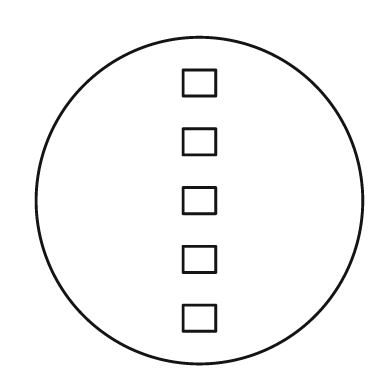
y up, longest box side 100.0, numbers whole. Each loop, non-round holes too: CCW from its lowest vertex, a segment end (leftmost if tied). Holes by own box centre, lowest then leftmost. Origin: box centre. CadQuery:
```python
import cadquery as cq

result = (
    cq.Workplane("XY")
    .moveTo(0.0, 0.0)
    .circle(50.0)
    .moveTo(-5.0, -40.0)
    .lineTo(5.0, -40.0)
    .lineTo(5.0, -32.0)
    .lineTo(-5.0, -32.0)
    .close()
    .moveTo(-5.0, -22.0)
    .lineTo(5.0, -22.0)
    .lineTo(5.0, -14.0)
    .lineTo(-5.0, -14.0)
    .close()
    .moveTo(-5.0, -4.0)
    .lineTo(5.0, -4.0)
    .lineTo(5.0, 4.0)
    .lineTo(-5.0, 4.0)
    .close()
    .moveTo(-5.0, 14.0)
    .lineTo(5.0, 14.0)
    .lineTo(5.0, 22.0)
    .lineTo(-5.0, 22.0)
    .close()
    .moveTo(-5.0, 32.0)
    .lineTo(5.0, 32.0)
    .lineTo(5.0, 40.0)
    .lineTo(-5.0, 40.0)
    .close()
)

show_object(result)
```